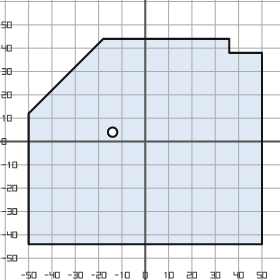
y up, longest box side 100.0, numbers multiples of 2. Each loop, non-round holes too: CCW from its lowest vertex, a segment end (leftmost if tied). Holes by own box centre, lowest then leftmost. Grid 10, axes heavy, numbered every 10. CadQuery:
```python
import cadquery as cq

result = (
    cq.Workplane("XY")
    .moveTo(-50.0, -44.0)
    .lineTo(50.0, -44.0)
    .lineTo(50.0, 38.0)
    .lineTo(36.0, 38.0)
    .lineTo(36.0, 44.0)
    .lineTo(-18.0, 44.0)
    .lineTo(-50.0, 12.0)
    .close()
    .moveTo(-14.0, 4.0)
    .circle(2.0)
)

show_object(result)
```